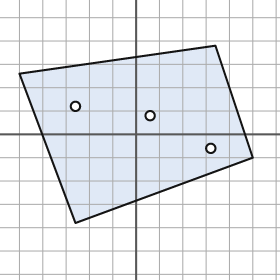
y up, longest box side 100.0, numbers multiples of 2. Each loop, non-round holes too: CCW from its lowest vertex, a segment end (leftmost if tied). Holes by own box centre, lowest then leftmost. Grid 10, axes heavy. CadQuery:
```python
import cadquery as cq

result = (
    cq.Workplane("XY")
    .moveTo(-26.0, -38.0)
    .lineTo(50.0, -10.0)
    .lineTo(34.0, 38.0)
    .lineTo(-50.0, 26.0)
    .close()
    .moveTo(32.0, -6.0)
    .circle(2.0)
    .moveTo(6.0, 8.0)
    .circle(2.0)
    .moveTo(-26.0, 12.0)
    .circle(2.0)
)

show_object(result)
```